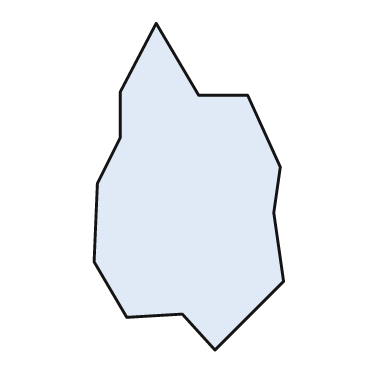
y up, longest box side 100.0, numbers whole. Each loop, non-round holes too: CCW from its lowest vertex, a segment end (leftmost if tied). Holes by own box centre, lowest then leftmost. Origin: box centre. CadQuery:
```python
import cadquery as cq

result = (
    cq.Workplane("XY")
    .moveTo(8.0, -50.0)
    .lineTo(29.0, -29.0)
    .lineTo(26.0, -8.0)
    .lineTo(28.0, 6.0)
    .lineTo(18.0, 28.0)
    .lineTo(3.0, 28.0)
    .lineTo(-10.0, 50.0)
    .lineTo(-21.0, 29.0)
    .lineTo(-21.0, 15.0)
    .lineTo(-28.0, 1.0)
    .lineTo(-29.0, -23.0)
    .lineTo(-19.0, -40.0)
    .lineTo(-2.0, -39.0)
    .close()
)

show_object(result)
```